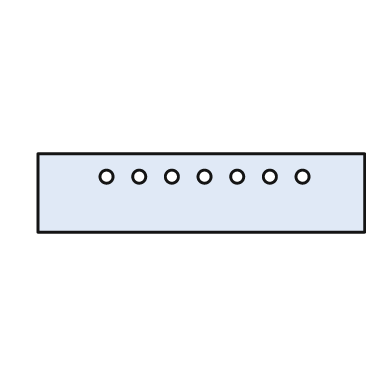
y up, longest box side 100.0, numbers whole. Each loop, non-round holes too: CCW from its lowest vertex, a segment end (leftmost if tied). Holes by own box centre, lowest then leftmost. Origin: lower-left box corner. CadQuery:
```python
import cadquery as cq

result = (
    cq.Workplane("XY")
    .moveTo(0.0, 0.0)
    .lineTo(100.0, 0.0)
    .lineTo(100.0, 24.0)
    .lineTo(0.0, 24.0)
    .close()
    .moveTo(21.0, 17.0)
    .circle(2.0)
    .moveTo(31.0, 17.0)
    .circle(2.0)
    .moveTo(41.0, 17.0)
    .circle(2.0)
    .moveTo(51.0, 17.0)
    .circle(2.0)
    .moveTo(61.0, 17.0)
    .circle(2.0)
    .moveTo(71.0, 17.0)
    .circle(2.0)
    .moveTo(81.0, 17.0)
    .circle(2.0)
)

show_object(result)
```